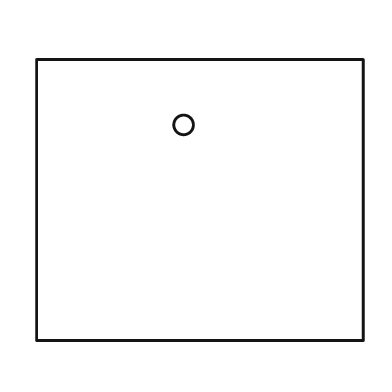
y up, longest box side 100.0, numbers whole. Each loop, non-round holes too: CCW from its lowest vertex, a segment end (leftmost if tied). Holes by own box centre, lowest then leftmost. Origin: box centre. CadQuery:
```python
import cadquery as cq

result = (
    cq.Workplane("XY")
    .moveTo(-50.0, -43.0)
    .lineTo(50.0, -43.0)
    .lineTo(50.0, 43.0)
    .lineTo(-50.0, 43.0)
    .close()
    .moveTo(-5.0, 23.0)
    .circle(3.0)
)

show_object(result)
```